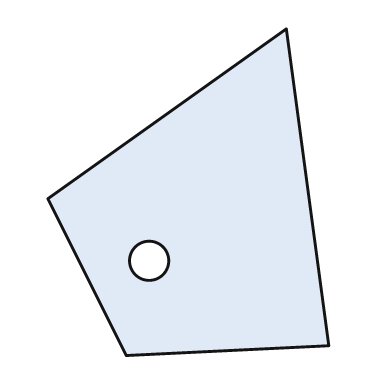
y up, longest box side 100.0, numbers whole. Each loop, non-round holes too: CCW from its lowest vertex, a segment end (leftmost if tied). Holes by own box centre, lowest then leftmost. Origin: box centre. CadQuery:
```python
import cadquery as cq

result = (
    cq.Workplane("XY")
    .moveTo(-19.0, -50.0)
    .lineTo(43.0, -47.0)
    .lineTo(30.0, 50.0)
    .lineTo(-43.0, -2.0)
    .close()
    .moveTo(-12.0, -21.0)
    .circle(6.0)
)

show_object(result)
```